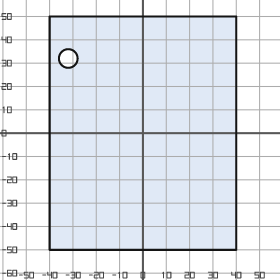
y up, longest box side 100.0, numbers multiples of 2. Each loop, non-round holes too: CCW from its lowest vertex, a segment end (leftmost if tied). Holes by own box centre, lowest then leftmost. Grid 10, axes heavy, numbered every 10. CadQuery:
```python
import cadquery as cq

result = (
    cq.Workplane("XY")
    .moveTo(-40.0, -50.0)
    .lineTo(40.0, -50.0)
    .lineTo(40.0, 50.0)
    .lineTo(-40.0, 50.0)
    .close()
    .moveTo(-32.0, 32.0)
    .circle(4.0)
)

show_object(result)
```